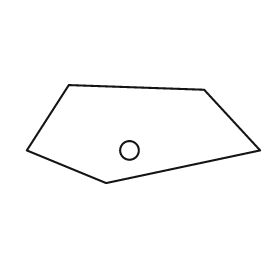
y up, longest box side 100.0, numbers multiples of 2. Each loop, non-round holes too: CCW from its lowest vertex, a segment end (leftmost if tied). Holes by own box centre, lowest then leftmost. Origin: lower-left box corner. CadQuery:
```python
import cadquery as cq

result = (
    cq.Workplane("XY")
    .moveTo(34.0, 0.0)
    .lineTo(100.0, 14.0)
    .lineTo(76.0, 40.0)
    .lineTo(18.0, 42.0)
    .lineTo(0.0, 14.0)
    .close()
    .moveTo(44.0, 14.0)
    .circle(4.0)
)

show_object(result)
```